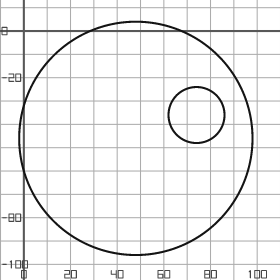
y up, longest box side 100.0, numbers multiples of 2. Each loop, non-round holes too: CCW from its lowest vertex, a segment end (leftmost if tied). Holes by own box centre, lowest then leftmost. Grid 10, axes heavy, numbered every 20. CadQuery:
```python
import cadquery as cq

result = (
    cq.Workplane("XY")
    .moveTo(48.0, -46.0)
    .circle(50.0)
    .moveTo(74.0, -36.0)
    .circle(12.0)
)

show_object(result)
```